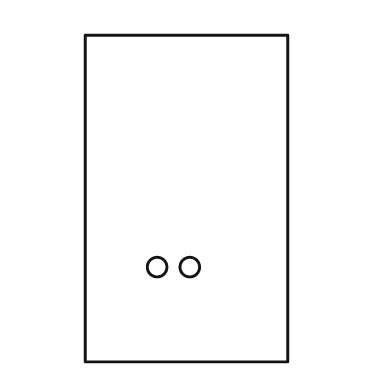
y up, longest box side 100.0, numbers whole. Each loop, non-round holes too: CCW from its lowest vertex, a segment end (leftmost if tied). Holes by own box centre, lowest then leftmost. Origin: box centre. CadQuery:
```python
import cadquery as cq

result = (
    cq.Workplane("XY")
    .moveTo(-31.0, -50.0)
    .lineTo(31.0, -50.0)
    .lineTo(31.0, 50.0)
    .lineTo(-31.0, 50.0)
    .close()
    .moveTo(-9.0, -21.0)
    .circle(3.0)
    .moveTo(1.0, -21.0)
    .circle(3.0)
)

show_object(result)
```